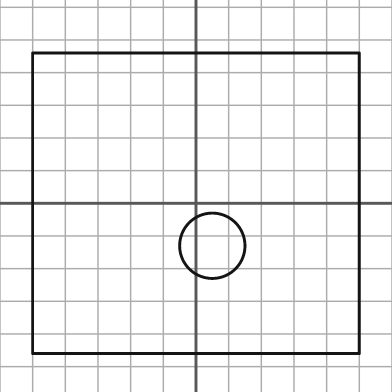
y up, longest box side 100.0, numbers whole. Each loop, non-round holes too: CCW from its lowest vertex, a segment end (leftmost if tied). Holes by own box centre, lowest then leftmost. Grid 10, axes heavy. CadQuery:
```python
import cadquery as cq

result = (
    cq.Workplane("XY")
    .moveTo(-50.0, -46.0)
    .lineTo(50.0, -46.0)
    .lineTo(50.0, 46.0)
    .lineTo(-50.0, 46.0)
    .close()
    .moveTo(5.0, -13.0)
    .circle(10.0)
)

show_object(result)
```